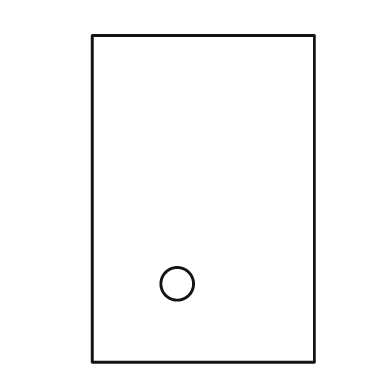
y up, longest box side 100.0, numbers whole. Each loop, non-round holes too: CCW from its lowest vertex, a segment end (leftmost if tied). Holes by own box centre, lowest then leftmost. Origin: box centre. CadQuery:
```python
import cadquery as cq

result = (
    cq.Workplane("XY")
    .moveTo(-34.0, -50.0)
    .lineTo(34.0, -50.0)
    .lineTo(34.0, 50.0)
    .lineTo(-34.0, 50.0)
    .close()
    .moveTo(-8.0, -26.0)
    .circle(5.0)
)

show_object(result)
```